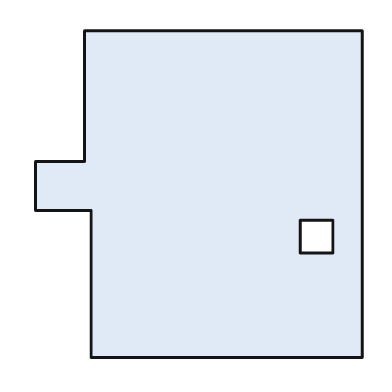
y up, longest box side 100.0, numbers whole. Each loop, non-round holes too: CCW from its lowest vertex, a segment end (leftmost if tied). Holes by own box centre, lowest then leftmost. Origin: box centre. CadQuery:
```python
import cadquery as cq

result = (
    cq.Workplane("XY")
    .moveTo(-33.0, -50.0)
    .lineTo(50.0, -50.0)
    .lineTo(50.0, 50.0)
    .lineTo(-35.0, 50.0)
    .lineTo(-35.0, 10.0)
    .lineTo(-50.0, 10.0)
    .lineTo(-50.0, -5.0)
    .lineTo(-33.0, -5.0)
    .close()
    .moveTo(31.0, -18.0)
    .lineTo(41.0, -18.0)
    .lineTo(41.0, -8.0)
    .lineTo(31.0, -8.0)
    .close()
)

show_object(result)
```